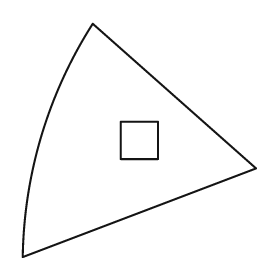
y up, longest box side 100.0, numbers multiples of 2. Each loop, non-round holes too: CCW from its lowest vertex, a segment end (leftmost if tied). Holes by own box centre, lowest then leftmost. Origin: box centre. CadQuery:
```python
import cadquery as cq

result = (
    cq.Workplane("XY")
    .moveTo(-50.0, -50.0)
    .lineTo(50.0, -12.0)
    .lineTo(-20.0, 50.0)
    .threePointArc((-42.0, 2.0), (-50.0, -50.0))
    .close()
    .moveTo(-8.0, -8.0)
    .lineTo(8.0, -8.0)
    .lineTo(8.0, 8.0)
    .lineTo(-8.0, 8.0)
    .close()
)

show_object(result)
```